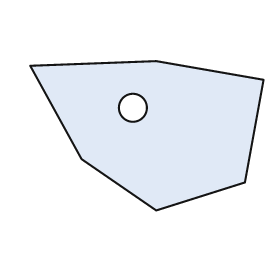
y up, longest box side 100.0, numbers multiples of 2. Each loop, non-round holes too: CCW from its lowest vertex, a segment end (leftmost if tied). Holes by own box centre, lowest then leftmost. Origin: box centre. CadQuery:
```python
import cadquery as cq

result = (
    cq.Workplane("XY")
    .moveTo(4.0, -32.0)
    .lineTo(42.0, -20.0)
    .lineTo(50.0, 24.0)
    .lineTo(4.0, 32.0)
    .lineTo(-50.0, 30.0)
    .lineTo(-28.0, -10.0)
    .close()
    .moveTo(-6.0, 12.0)
    .circle(6.0)
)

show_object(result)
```